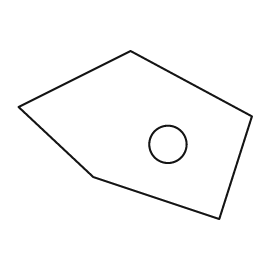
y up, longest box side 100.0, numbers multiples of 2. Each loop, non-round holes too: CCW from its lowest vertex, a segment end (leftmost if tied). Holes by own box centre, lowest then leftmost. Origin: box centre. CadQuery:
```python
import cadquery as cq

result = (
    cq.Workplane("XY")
    .moveTo(36.0, -36.0)
    .lineTo(50.0, 8.0)
    .lineTo(-2.0, 36.0)
    .lineTo(-50.0, 12.0)
    .lineTo(-18.0, -18.0)
    .close()
    .moveTo(14.0, -4.0)
    .circle(8.0)
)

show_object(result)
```